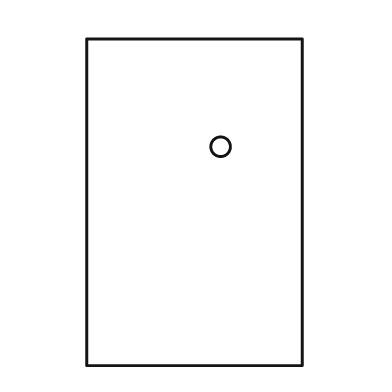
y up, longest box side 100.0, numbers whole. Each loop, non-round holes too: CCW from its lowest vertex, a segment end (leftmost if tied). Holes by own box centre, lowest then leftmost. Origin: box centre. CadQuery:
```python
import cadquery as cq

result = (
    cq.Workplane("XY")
    .moveTo(-33.0, -50.0)
    .lineTo(33.0, -50.0)
    .lineTo(33.0, 50.0)
    .lineTo(-33.0, 50.0)
    .close()
    .moveTo(8.0, 17.0)
    .circle(3.0)
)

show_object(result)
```